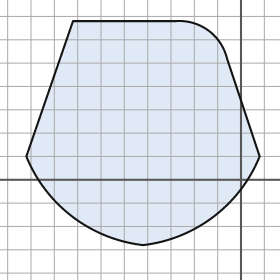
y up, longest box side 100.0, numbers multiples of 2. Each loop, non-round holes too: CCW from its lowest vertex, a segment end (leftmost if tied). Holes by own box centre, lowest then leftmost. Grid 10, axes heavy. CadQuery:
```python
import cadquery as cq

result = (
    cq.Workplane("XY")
    .moveTo(-42.0, -28.0)
    .threePointArc((-12.0, -16.0), (8.0, 10.0))
    .lineTo(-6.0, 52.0)
    .threePointArc((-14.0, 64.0), (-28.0, 68.0))
    .lineTo(-72.0, 68.0)
    .lineTo(-92.0, 10.0)
    .threePointArc((-72.0, -16.0), (-42.0, -28.0))
    .close()
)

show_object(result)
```